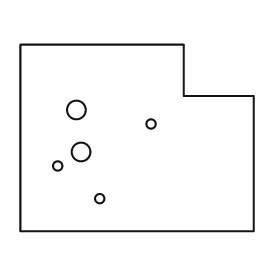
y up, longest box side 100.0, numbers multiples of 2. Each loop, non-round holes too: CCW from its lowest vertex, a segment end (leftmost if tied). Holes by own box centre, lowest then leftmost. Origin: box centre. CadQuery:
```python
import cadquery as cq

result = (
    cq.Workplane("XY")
    .moveTo(-50.0, -40.0)
    .lineTo(50.0, -40.0)
    .lineTo(50.0, 18.0)
    .lineTo(20.0, 18.0)
    .lineTo(20.0, 40.0)
    .lineTo(-50.0, 40.0)
    .close()
    .moveTo(-16.0, -26.0)
    .circle(2.0)
    .moveTo(-34.0, -12.0)
    .circle(2.0)
    .moveTo(-24.0, -6.0)
    .circle(4.0)
    .moveTo(6.0, 6.0)
    .circle(2.0)
    .moveTo(-26.0, 12.0)
    .circle(4.0)
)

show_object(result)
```